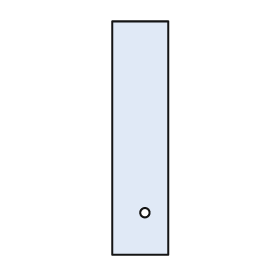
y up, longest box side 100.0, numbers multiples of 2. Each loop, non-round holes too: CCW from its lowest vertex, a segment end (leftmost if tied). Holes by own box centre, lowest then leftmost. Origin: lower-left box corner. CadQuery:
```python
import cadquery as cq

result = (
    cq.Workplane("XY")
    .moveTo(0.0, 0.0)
    .lineTo(24.0, 0.0)
    .lineTo(24.0, 100.0)
    .lineTo(0.0, 100.0)
    .close()
    .moveTo(14.0, 18.0)
    .circle(2.0)
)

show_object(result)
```